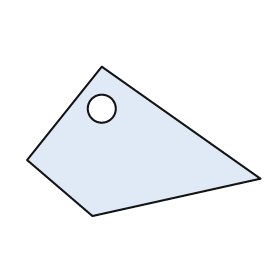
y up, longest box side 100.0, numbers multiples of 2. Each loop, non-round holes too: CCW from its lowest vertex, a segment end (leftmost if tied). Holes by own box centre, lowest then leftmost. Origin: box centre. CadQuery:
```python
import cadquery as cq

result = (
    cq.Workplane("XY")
    .moveTo(-22.0, -32.0)
    .lineTo(50.0, -16.0)
    .lineTo(-18.0, 32.0)
    .lineTo(-50.0, -8.0)
    .close()
    .moveTo(-18.0, 14.0)
    .circle(6.0)
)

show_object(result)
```